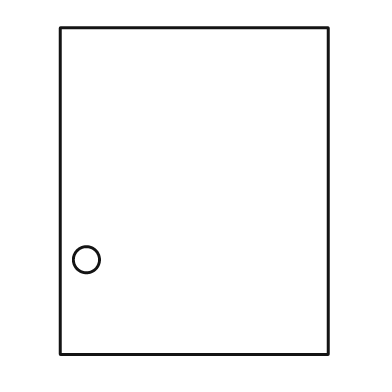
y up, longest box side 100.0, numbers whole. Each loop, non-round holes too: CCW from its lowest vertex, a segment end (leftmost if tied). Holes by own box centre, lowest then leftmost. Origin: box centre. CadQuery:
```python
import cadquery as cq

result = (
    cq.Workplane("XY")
    .moveTo(-41.0, -50.0)
    .lineTo(41.0, -50.0)
    .lineTo(41.0, 50.0)
    .lineTo(-41.0, 50.0)
    .close()
    .moveTo(-33.0, -21.0)
    .circle(4.0)
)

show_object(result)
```